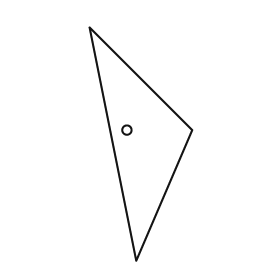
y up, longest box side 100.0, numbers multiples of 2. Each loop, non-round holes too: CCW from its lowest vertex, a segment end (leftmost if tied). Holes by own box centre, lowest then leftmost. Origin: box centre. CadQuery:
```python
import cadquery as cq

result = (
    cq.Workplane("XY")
    .moveTo(-2.0, -50.0)
    .lineTo(22.0, 6.0)
    .lineTo(-22.0, 50.0)
    .close()
    .moveTo(-6.0, 6.0)
    .circle(2.0)
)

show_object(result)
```